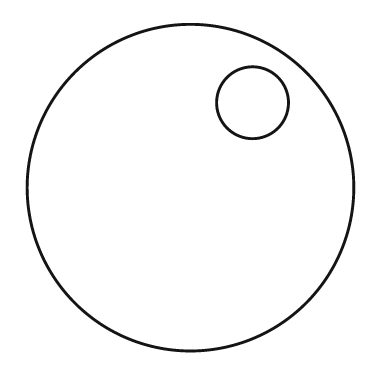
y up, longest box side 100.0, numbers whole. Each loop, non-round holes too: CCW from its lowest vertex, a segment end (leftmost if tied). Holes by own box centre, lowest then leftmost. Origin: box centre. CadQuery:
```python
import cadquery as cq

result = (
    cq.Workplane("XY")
    .moveTo(0.0, 0.0)
    .circle(50.0)
    .moveTo(19.0, 26.0)
    .circle(11.0)
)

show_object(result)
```